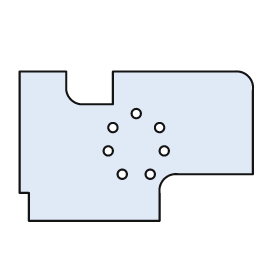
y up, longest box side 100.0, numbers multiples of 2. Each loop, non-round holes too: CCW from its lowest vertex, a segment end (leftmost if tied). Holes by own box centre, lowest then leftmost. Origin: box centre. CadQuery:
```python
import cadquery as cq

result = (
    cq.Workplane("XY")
    .moveTo(-46.0, -32.0)
    .lineTo(10.0, -32.0)
    .lineTo(10.0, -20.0)
    .threePointArc((12.0, -14.0), (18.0, -12.0))
    .lineTo(50.0, -12.0)
    .lineTo(50.0, 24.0)
    .threePointArc((48.0, 30.0), (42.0, 32.0))
    .lineTo(-10.0, 32.0)
    .lineTo(-10.0, 18.0)
    .lineTo(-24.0, 18.0)
    .threePointArc((-28.0, 20.0), (-30.0, 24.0))
    .lineTo(-30.0, 32.0)
    .lineTo(-50.0, 32.0)
    .lineTo(-50.0, -20.0)
    .lineTo(-46.0, -20.0)
    .close()
    .moveTo(-6.0, -12.0)
    .circle(2.0)
    .moveTo(6.0, -12.0)
    .circle(2.0)
    .moveTo(-12.0, -2.0)
    .circle(2.0)
    .moveTo(12.0, -2.0)
    .circle(2.0)
    .moveTo(-10.0, 8.0)
    .circle(2.0)
    .moveTo(10.0, 8.0)
    .circle(2.0)
    .moveTo(0.0, 14.0)
    .circle(2.0)
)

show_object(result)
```